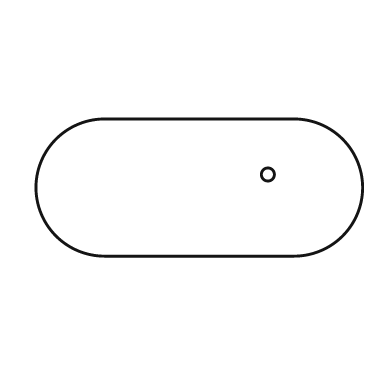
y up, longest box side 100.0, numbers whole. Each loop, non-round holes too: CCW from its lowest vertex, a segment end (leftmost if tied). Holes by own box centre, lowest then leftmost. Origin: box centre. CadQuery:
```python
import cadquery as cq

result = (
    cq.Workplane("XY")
    .moveTo(-29.0, -21.0)
    .lineTo(29.0, -21.0)
    .threePointArc((50.0, 0.0), (29.0, 21.0))
    .lineTo(-29.0, 21.0)
    .threePointArc((-50.0, 0.0), (-29.0, -21.0))
    .close()
    .moveTo(21.0, 4.0)
    .circle(2.0)
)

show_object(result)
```